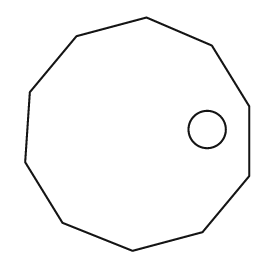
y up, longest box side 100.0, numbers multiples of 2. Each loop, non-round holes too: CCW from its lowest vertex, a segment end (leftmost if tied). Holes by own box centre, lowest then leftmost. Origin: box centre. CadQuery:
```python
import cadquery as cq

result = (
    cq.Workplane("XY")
    .moveTo(-2.0, -50.0)
    .lineTo(28.0, -42.0)
    .lineTo(48.0, -18.0)
    .lineTo(48.0, 12.0)
    .lineTo(32.0, 38.0)
    .lineTo(4.0, 50.0)
    .lineTo(-26.0, 42.0)
    .lineTo(-46.0, 18.0)
    .lineTo(-48.0, -12.0)
    .lineTo(-32.0, -38.0)
    .close()
    .moveTo(30.0, 2.0)
    .circle(8.0)
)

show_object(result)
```